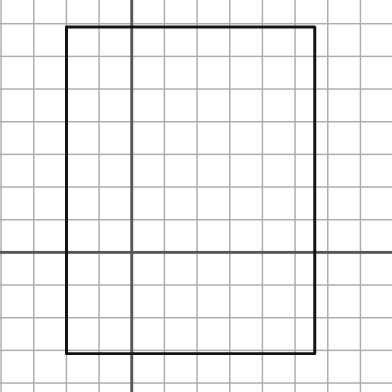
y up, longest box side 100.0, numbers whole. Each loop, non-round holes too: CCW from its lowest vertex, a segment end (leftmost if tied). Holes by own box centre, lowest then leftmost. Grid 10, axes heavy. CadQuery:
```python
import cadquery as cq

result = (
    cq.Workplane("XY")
    .moveTo(-20.0, -31.0)
    .lineTo(56.0, -31.0)
    .lineTo(56.0, 69.0)
    .lineTo(-20.0, 69.0)
    .close()
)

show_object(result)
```